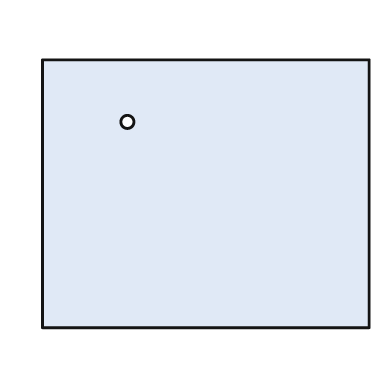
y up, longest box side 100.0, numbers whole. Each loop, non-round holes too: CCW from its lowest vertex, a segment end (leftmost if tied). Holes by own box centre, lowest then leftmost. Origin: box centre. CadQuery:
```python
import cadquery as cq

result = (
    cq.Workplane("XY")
    .moveTo(-50.0, -41.0)
    .lineTo(50.0, -41.0)
    .lineTo(50.0, 41.0)
    .lineTo(-50.0, 41.0)
    .close()
    .moveTo(-24.0, 22.0)
    .circle(2.0)
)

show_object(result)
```